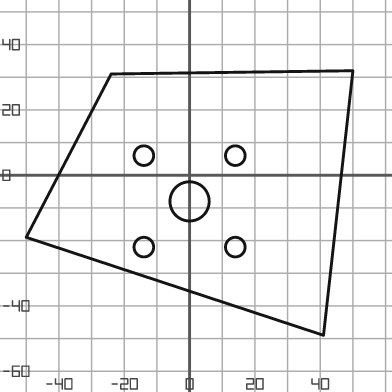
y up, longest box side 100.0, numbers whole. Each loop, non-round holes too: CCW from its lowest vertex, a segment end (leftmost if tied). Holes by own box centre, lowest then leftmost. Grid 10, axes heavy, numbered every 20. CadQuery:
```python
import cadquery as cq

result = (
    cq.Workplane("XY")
    .moveTo(41.0, -49.0)
    .lineTo(50.0, 32.0)
    .lineTo(-24.0, 31.0)
    .lineTo(-50.0, -19.0)
    .close()
    .moveTo(-14.0, -22.0)
    .circle(3.0)
    .moveTo(14.0, -22.0)
    .circle(3.0)
    .moveTo(0.0, -8.0)
    .circle(6.0)
    .moveTo(-14.0, 6.0)
    .circle(3.0)
    .moveTo(14.0, 6.0)
    .circle(3.0)
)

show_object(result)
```